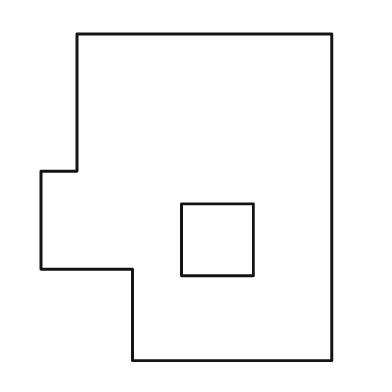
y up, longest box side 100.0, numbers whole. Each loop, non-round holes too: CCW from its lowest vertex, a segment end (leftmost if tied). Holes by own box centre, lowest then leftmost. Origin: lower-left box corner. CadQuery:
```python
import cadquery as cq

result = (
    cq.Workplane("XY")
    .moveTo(28.0, 0.0)
    .lineTo(89.0, 0.0)
    .lineTo(89.0, 100.0)
    .lineTo(11.0, 100.0)
    .lineTo(11.0, 58.0)
    .lineTo(0.0, 58.0)
    .lineTo(0.0, 28.0)
    .lineTo(28.0, 28.0)
    .close()
    .moveTo(43.0, 26.0)
    .lineTo(65.0, 26.0)
    .lineTo(65.0, 48.0)
    .lineTo(43.0, 48.0)
    .close()
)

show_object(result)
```